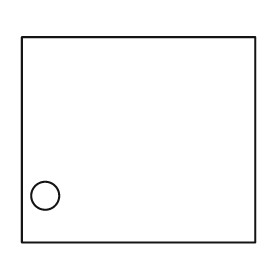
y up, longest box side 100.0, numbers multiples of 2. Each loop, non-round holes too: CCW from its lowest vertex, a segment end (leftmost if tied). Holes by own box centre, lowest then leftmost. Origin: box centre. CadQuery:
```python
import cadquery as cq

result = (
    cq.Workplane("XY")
    .moveTo(-50.0, -44.0)
    .lineTo(50.0, -44.0)
    .lineTo(50.0, 44.0)
    .lineTo(-50.0, 44.0)
    .close()
    .moveTo(-40.0, -24.0)
    .circle(6.0)
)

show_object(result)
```